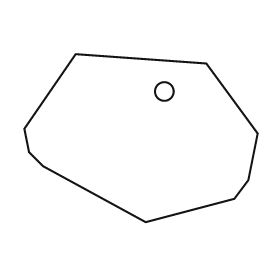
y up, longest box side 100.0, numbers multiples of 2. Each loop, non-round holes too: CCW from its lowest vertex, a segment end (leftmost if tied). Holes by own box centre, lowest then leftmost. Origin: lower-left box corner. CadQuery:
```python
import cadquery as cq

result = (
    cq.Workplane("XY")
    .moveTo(52.0, 0.0)
    .lineTo(90.0, 10.0)
    .lineTo(96.0, 18.0)
    .lineTo(100.0, 38.0)
    .lineTo(78.0, 68.0)
    .lineTo(22.0, 72.0)
    .lineTo(0.0, 40.0)
    .lineTo(2.0, 30.0)
    .lineTo(8.0, 24.0)
    .close()
    .moveTo(60.0, 56.0)
    .circle(4.0)
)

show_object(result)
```